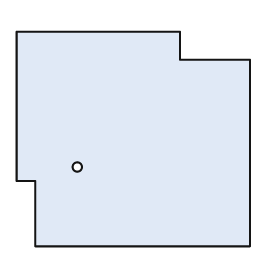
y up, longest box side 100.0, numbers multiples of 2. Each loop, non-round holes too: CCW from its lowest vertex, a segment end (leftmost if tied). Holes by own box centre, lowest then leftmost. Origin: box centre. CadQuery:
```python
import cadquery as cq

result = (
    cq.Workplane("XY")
    .moveTo(-42.0, -46.0)
    .lineTo(50.0, -46.0)
    .lineTo(50.0, 34.0)
    .lineTo(20.0, 34.0)
    .lineTo(20.0, 46.0)
    .lineTo(-50.0, 46.0)
    .lineTo(-50.0, -18.0)
    .lineTo(-42.0, -18.0)
    .close()
    .moveTo(-24.0, -12.0)
    .circle(2.0)
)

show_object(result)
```